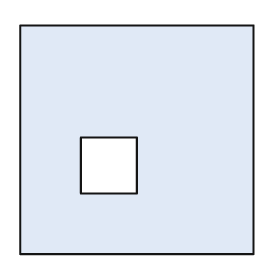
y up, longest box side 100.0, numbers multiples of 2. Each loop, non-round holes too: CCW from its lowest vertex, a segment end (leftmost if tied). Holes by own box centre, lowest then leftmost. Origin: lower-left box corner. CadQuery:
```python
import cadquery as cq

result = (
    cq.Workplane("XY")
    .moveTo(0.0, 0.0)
    .lineTo(100.0, 0.0)
    .lineTo(100.0, 98.0)
    .lineTo(0.0, 98.0)
    .close()
    .moveTo(26.0, 26.0)
    .lineTo(50.0, 26.0)
    .lineTo(50.0, 50.0)
    .lineTo(26.0, 50.0)
    .close()
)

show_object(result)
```